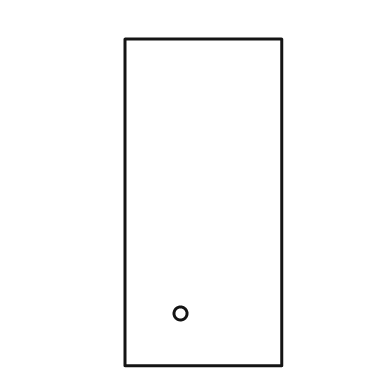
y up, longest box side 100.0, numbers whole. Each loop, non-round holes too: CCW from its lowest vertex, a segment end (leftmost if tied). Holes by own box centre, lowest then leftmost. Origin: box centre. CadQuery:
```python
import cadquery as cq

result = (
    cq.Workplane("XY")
    .moveTo(-24.0, -50.0)
    .lineTo(24.0, -50.0)
    .lineTo(24.0, 50.0)
    .lineTo(-24.0, 50.0)
    .close()
    .moveTo(-7.0, -34.0)
    .circle(2.0)
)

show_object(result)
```